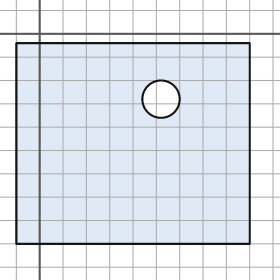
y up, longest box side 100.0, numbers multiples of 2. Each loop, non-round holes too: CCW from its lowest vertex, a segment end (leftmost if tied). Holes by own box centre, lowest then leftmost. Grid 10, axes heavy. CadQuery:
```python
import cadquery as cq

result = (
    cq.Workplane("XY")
    .moveTo(-10.0, -90.0)
    .lineTo(90.0, -90.0)
    .lineTo(90.0, -4.0)
    .lineTo(-10.0, -4.0)
    .close()
    .moveTo(52.0, -28.0)
    .circle(8.0)
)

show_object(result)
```